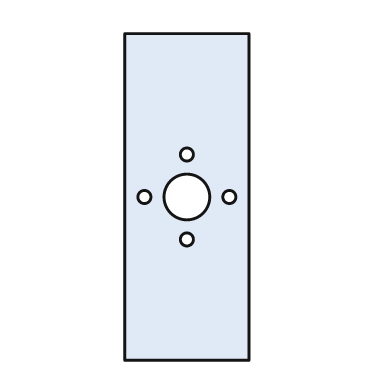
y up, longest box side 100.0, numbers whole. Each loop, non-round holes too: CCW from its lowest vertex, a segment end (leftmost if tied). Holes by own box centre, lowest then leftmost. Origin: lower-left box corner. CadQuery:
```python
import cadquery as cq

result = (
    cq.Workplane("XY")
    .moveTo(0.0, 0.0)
    .lineTo(38.0, 0.0)
    .lineTo(38.0, 100.0)
    .lineTo(0.0, 100.0)
    .close()
    .moveTo(19.0, 37.0)
    .circle(2.0)
    .moveTo(6.0, 50.0)
    .circle(2.0)
    .moveTo(19.0, 50.0)
    .circle(7.0)
    .moveTo(32.0, 50.0)
    .circle(2.0)
    .moveTo(19.0, 63.0)
    .circle(2.0)
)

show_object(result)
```